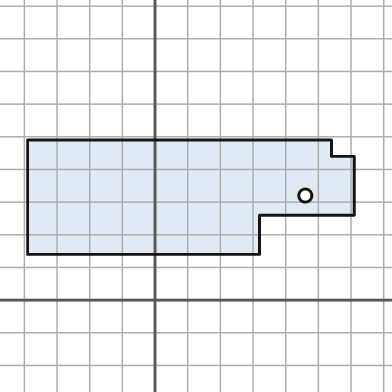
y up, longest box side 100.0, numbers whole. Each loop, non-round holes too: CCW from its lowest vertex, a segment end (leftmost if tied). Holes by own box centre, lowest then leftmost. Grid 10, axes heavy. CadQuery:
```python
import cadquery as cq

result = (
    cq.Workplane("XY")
    .moveTo(-39.0, 14.0)
    .lineTo(32.0, 14.0)
    .lineTo(32.0, 26.0)
    .lineTo(61.0, 26.0)
    .lineTo(61.0, 44.0)
    .lineTo(54.0, 44.0)
    .lineTo(54.0, 49.0)
    .lineTo(-39.0, 49.0)
    .close()
    .moveTo(46.0, 32.0)
    .circle(2.0)
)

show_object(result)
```